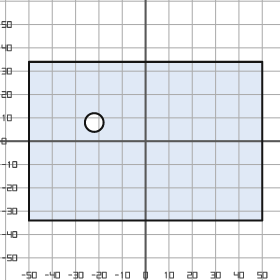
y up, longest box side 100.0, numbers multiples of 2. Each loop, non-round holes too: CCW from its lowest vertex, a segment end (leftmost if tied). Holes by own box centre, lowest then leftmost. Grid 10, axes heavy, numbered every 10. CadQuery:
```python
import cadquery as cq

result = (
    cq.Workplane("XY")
    .moveTo(-50.0, -34.0)
    .lineTo(50.0, -34.0)
    .lineTo(50.0, 34.0)
    .lineTo(-50.0, 34.0)
    .close()
    .moveTo(-22.0, 8.0)
    .circle(4.0)
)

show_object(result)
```